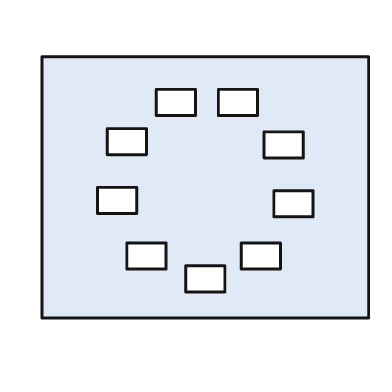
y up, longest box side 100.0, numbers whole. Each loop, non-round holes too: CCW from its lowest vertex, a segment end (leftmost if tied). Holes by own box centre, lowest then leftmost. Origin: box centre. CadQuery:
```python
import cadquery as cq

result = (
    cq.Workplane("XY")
    .moveTo(-50.0, -40.0)
    .lineTo(50.0, -40.0)
    .lineTo(50.0, 40.0)
    .lineTo(-50.0, 40.0)
    .close()
    .moveTo(-6.0, -32.0)
    .lineTo(6.0, -32.0)
    .lineTo(6.0, -24.0)
    .lineTo(-6.0, -24.0)
    .close()
    .moveTo(-24.0, -25.0)
    .lineTo(-12.0, -25.0)
    .lineTo(-12.0, -17.0)
    .lineTo(-24.0, -17.0)
    .close()
    .moveTo(11.0, -25.0)
    .lineTo(23.0, -25.0)
    .lineTo(23.0, -17.0)
    .lineTo(11.0, -17.0)
    .close()
    .moveTo(21.0, -9.0)
    .lineTo(33.0, -9.0)
    .lineTo(33.0, -1.0)
    .lineTo(21.0, -1.0)
    .close()
    .moveTo(-33.0, -8.0)
    .lineTo(-21.0, -8.0)
    .lineTo(-21.0, 0.0)
    .lineTo(-33.0, 0.0)
    .close()
    .moveTo(18.0, 9.0)
    .lineTo(30.0, 9.0)
    .lineTo(30.0, 17.0)
    .lineTo(18.0, 17.0)
    .close()
    .moveTo(-30.0, 10.0)
    .lineTo(-18.0, 10.0)
    .lineTo(-18.0, 18.0)
    .lineTo(-30.0, 18.0)
    .close()
    .moveTo(-15.0, 22.0)
    .lineTo(-3.0, 22.0)
    .lineTo(-3.0, 30.0)
    .lineTo(-15.0, 30.0)
    .close()
    .moveTo(4.0, 22.0)
    .lineTo(16.0, 22.0)
    .lineTo(16.0, 30.0)
    .lineTo(4.0, 30.0)
    .close()
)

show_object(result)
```